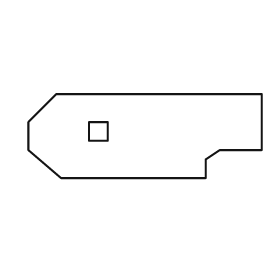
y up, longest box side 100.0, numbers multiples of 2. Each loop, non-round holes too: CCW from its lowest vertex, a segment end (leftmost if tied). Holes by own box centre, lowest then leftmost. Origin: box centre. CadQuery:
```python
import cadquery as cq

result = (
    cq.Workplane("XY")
    .moveTo(-36.0, -18.0)
    .lineTo(26.0, -18.0)
    .lineTo(26.0, -10.0)
    .lineTo(32.0, -6.0)
    .lineTo(50.0, -6.0)
    .lineTo(50.0, 18.0)
    .lineTo(-38.0, 18.0)
    .lineTo(-50.0, 6.0)
    .lineTo(-50.0, -6.0)
    .close()
    .moveTo(-24.0, -2.0)
    .lineTo(-16.0, -2.0)
    .lineTo(-16.0, 6.0)
    .lineTo(-24.0, 6.0)
    .close()
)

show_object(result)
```